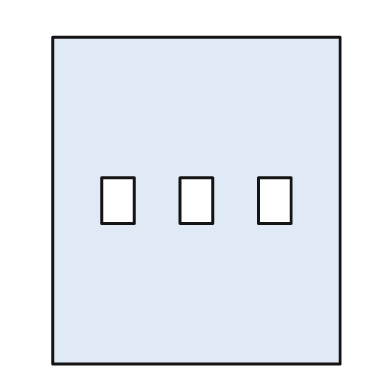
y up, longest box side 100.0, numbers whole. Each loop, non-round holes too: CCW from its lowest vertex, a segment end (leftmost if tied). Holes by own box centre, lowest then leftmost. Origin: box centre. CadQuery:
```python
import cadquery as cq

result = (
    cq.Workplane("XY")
    .moveTo(-44.0, -50.0)
    .lineTo(44.0, -50.0)
    .lineTo(44.0, 50.0)
    .lineTo(-44.0, 50.0)
    .close()
    .moveTo(-29.0, -7.0)
    .lineTo(-19.0, -7.0)
    .lineTo(-19.0, 7.0)
    .lineTo(-29.0, 7.0)
    .close()
    .moveTo(-5.0, -7.0)
    .lineTo(5.0, -7.0)
    .lineTo(5.0, 7.0)
    .lineTo(-5.0, 7.0)
    .close()
    .moveTo(19.0, -7.0)
    .lineTo(29.0, -7.0)
    .lineTo(29.0, 7.0)
    .lineTo(19.0, 7.0)
    .close()
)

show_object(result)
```